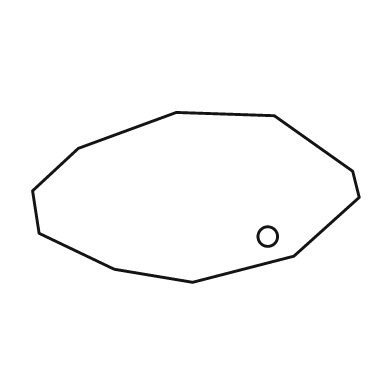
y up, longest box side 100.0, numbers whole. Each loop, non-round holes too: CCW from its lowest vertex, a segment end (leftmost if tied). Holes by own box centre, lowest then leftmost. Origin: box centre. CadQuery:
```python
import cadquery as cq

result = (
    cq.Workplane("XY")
    .moveTo(-1.0, -26.0)
    .lineTo(30.0, -18.0)
    .lineTo(50.0, 0.0)
    .lineTo(48.0, 8.0)
    .lineTo(24.0, 25.0)
    .lineTo(-6.0, 26.0)
    .lineTo(-36.0, 15.0)
    .lineTo(-50.0, 2.0)
    .lineTo(-48.0, -11.0)
    .lineTo(-25.0, -22.0)
    .close()
    .moveTo(22.0, -12.0)
    .circle(3.0)
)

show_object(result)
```